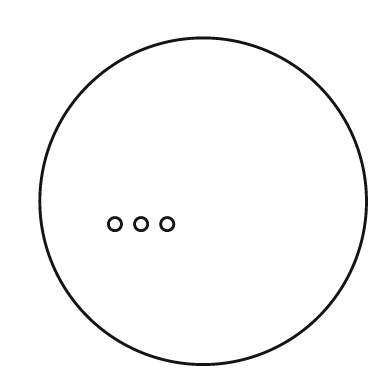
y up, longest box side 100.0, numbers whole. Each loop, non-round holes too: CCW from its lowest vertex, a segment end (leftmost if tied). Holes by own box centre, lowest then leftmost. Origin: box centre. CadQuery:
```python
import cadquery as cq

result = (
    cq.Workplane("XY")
    .moveTo(0.0, 0.0)
    .circle(50.0)
    .moveTo(-27.0, -7.0)
    .circle(2.0)
    .moveTo(-19.0, -7.0)
    .circle(2.0)
    .moveTo(-11.0, -7.0)
    .circle(2.0)
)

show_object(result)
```